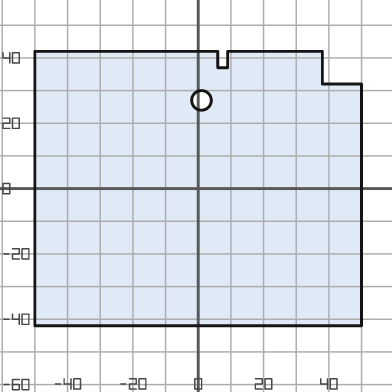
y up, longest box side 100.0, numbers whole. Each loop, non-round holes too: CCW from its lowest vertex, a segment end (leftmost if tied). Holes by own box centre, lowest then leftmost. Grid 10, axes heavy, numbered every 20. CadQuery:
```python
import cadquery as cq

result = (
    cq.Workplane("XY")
    .moveTo(-50.0, -42.0)
    .lineTo(50.0, -42.0)
    .lineTo(50.0, 32.0)
    .lineTo(38.0, 32.0)
    .lineTo(38.0, 42.0)
    .lineTo(9.0, 42.0)
    .lineTo(9.0, 37.0)
    .lineTo(6.0, 37.0)
    .lineTo(6.0, 42.0)
    .lineTo(-50.0, 42.0)
    .close()
    .moveTo(1.0, 27.0)
    .circle(3.0)
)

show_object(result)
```